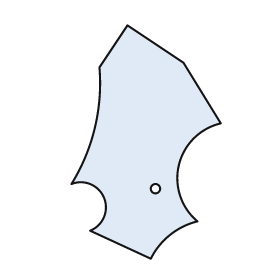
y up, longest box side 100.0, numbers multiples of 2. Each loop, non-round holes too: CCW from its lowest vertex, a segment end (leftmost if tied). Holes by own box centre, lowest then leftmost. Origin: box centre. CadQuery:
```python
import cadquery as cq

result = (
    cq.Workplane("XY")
    .moveTo(2.0, -50.0)
    .threePointArc((10.0, -40.0), (22.0, -34.0))
    .threePointArc((14.0, -10.0), (32.0, 8.0))
    .lineTo(16.0, 34.0)
    .lineTo(-8.0, 50.0)
    .lineTo(-20.0, 32.0)
    .threePointArc((-22.0, 6.0), (-32.0, -18.0))
    .threePointArc((-18.0, -24.0), (-24.0, -38.0))
    .close()
    .moveTo(4.0, -20.0)
    .circle(2.0)
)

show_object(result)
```